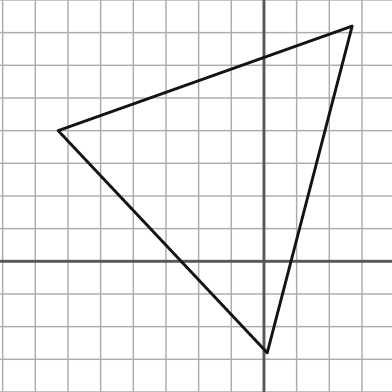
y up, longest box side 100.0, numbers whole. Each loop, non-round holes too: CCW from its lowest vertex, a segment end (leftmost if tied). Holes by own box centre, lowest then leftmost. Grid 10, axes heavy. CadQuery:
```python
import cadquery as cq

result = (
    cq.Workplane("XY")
    .moveTo(1.0, -28.0)
    .lineTo(27.0, 72.0)
    .lineTo(-63.0, 40.0)
    .close()
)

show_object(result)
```